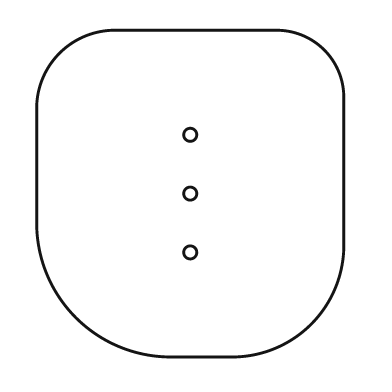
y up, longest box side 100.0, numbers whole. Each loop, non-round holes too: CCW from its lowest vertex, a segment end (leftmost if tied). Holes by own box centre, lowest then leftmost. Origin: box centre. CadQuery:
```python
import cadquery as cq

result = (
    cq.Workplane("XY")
    .moveTo(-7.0, -50.0)
    .lineTo(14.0, -50.0)
    .threePointArc((37.0, -40.0), (47.0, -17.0))
    .lineTo(47.0, 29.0)
    .threePointArc((41.0, 44.0), (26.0, 50.0))
    .lineTo(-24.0, 50.0)
    .threePointArc((-40.0, 43.0), (-47.0, 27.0))
    .lineTo(-47.0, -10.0)
    .threePointArc((-35.0, -38.0), (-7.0, -50.0))
    .close()
    .moveTo(0.0, -18.0)
    .circle(2.0)
    .moveTo(0.0, 0.0)
    .circle(2.0)
    .moveTo(0.0, 18.0)
    .circle(2.0)
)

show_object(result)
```